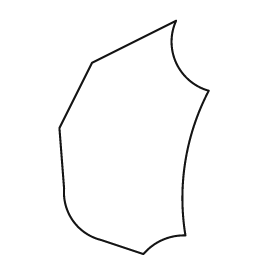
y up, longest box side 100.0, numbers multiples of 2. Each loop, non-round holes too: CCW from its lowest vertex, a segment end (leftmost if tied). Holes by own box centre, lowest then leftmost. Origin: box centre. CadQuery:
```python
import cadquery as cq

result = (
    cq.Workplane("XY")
    .moveTo(4.0, -50.0)
    .threePointArc((12.0, -44.0), (22.0, -42.0))
    .threePointArc((22.0, -10.0), (32.0, 20.0))
    .threePointArc((18.0, 32.0), (18.0, 50.0))
    .lineTo(-18.0, 32.0)
    .lineTo(-32.0, 4.0)
    .lineTo(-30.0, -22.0)
    .threePointArc((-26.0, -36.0), (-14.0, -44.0))
    .close()
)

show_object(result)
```